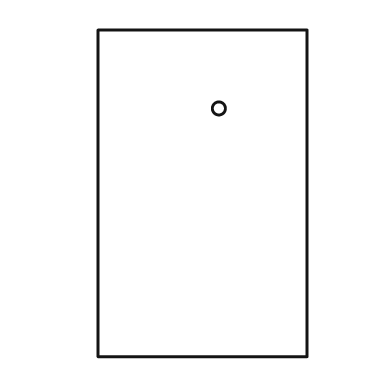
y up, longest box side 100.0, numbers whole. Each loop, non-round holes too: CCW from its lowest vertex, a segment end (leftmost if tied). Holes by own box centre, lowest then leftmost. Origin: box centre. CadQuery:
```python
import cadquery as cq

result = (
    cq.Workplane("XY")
    .moveTo(-32.0, -50.0)
    .lineTo(32.0, -50.0)
    .lineTo(32.0, 50.0)
    .lineTo(-32.0, 50.0)
    .close()
    .moveTo(5.0, 26.0)
    .circle(2.0)
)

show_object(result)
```